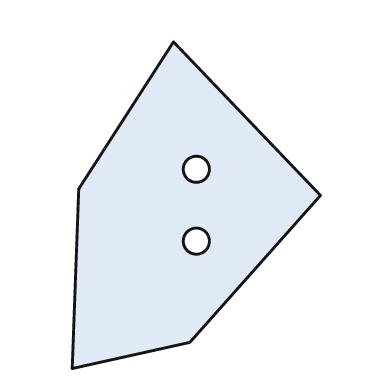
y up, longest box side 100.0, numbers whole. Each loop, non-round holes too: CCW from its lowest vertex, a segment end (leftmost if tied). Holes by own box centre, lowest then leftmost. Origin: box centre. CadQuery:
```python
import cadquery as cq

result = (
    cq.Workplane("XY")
    .moveTo(-38.0, -50.0)
    .lineTo(-2.0, -42.0)
    .lineTo(38.0, 3.0)
    .lineTo(-7.0, 50.0)
    .lineTo(-36.0, 5.0)
    .close()
    .moveTo(0.0, -11.0)
    .circle(4.0)
    .moveTo(0.0, 11.0)
    .circle(4.0)
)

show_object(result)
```